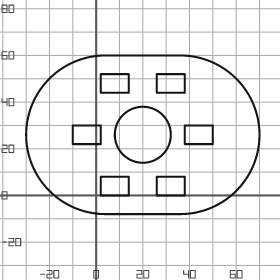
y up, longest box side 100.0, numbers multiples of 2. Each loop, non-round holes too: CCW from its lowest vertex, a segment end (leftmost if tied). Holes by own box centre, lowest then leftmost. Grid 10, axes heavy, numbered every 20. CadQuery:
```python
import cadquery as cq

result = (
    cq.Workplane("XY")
    .moveTo(4.0, -8.0)
    .lineTo(36.0, -8.0)
    .threePointArc((70.0, 26.0), (36.0, 60.0))
    .lineTo(4.0, 60.0)
    .threePointArc((-30.0, 26.0), (4.0, -8.0))
    .close()
    .moveTo(2.0, 0.0)
    .lineTo(14.0, 0.0)
    .lineTo(14.0, 8.0)
    .lineTo(2.0, 8.0)
    .close()
    .moveTo(26.0, 0.0)
    .lineTo(38.0, 0.0)
    .lineTo(38.0, 8.0)
    .lineTo(26.0, 8.0)
    .close()
    .moveTo(-10.0, 22.0)
    .lineTo(2.0, 22.0)
    .lineTo(2.0, 30.0)
    .lineTo(-10.0, 30.0)
    .close()
    .moveTo(20.0, 26.0)
    .circle(12.0)
    .moveTo(38.0, 22.0)
    .lineTo(50.0, 22.0)
    .lineTo(50.0, 30.0)
    .lineTo(38.0, 30.0)
    .close()
    .moveTo(2.0, 44.0)
    .lineTo(14.0, 44.0)
    .lineTo(14.0, 52.0)
    .lineTo(2.0, 52.0)
    .close()
    .moveTo(26.0, 44.0)
    .lineTo(38.0, 44.0)
    .lineTo(38.0, 52.0)
    .lineTo(26.0, 52.0)
    .close()
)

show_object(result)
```